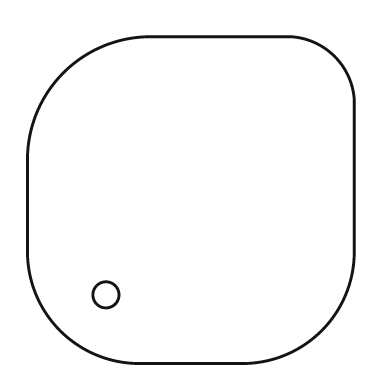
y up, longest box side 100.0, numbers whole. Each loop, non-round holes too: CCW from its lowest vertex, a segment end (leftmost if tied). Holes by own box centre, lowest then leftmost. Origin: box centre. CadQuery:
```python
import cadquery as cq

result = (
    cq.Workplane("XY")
    .moveTo(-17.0, -50.0)
    .lineTo(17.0, -50.0)
    .threePointArc((40.0, -40.0), (50.0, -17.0))
    .lineTo(50.0, 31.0)
    .threePointArc((44.0, 44.0), (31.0, 50.0))
    .lineTo(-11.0, 50.0)
    .threePointArc((-39.0, 39.0), (-50.0, 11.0))
    .lineTo(-50.0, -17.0)
    .threePointArc((-40.0, -40.0), (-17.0, -50.0))
    .close()
    .moveTo(-26.0, -29.0)
    .circle(4.0)
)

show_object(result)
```